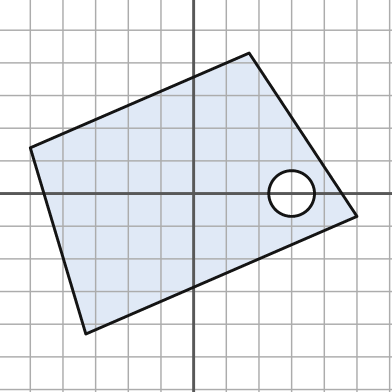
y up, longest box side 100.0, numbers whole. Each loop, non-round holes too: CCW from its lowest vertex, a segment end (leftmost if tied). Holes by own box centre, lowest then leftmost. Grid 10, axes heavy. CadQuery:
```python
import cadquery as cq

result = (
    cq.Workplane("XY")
    .moveTo(-33.0, -43.0)
    .lineTo(50.0, -7.0)
    .lineTo(17.0, 43.0)
    .lineTo(-50.0, 14.0)
    .close()
    .moveTo(30.0, 0.0)
    .circle(7.0)
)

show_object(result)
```